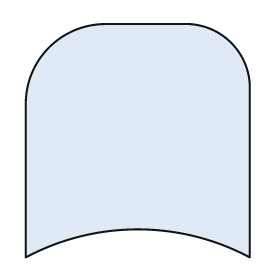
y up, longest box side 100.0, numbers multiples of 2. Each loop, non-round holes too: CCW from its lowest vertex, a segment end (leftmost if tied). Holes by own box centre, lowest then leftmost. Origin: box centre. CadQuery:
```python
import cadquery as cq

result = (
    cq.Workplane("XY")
    .moveTo(-48.0, -50.0)
    .threePointArc((0.0, -38.0), (48.0, -50.0))
    .lineTo(48.0, 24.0)
    .threePointArc((40.0, 42.0), (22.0, 50.0))
    .lineTo(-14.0, 50.0)
    .threePointArc((-38.0, 40.0), (-48.0, 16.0))
    .close()
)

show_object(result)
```